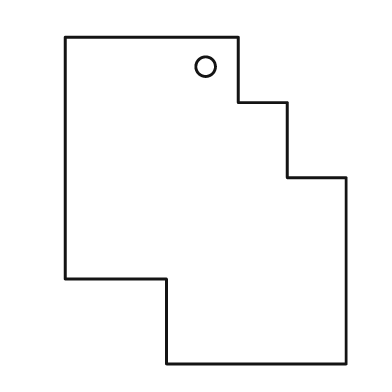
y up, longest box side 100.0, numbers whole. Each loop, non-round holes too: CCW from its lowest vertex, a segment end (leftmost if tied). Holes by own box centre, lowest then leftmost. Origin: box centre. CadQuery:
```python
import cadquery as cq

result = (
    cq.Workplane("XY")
    .moveTo(-12.0, -50.0)
    .lineTo(43.0, -50.0)
    .lineTo(43.0, 7.0)
    .lineTo(25.0, 7.0)
    .lineTo(25.0, 30.0)
    .lineTo(10.0, 30.0)
    .lineTo(10.0, 50.0)
    .lineTo(-43.0, 50.0)
    .lineTo(-43.0, -24.0)
    .lineTo(-12.0, -24.0)
    .close()
    .moveTo(0.0, 41.0)
    .circle(3.0)
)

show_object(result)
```